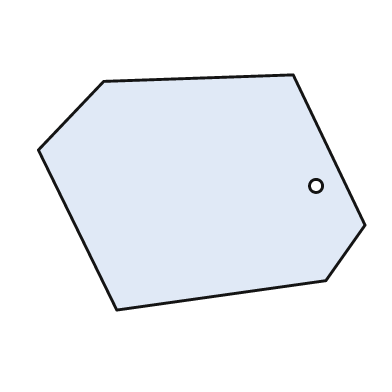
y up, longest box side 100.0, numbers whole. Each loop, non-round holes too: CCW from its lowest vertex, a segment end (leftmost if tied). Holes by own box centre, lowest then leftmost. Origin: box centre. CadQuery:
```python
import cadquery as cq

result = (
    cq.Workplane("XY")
    .moveTo(-26.0, -36.0)
    .lineTo(38.0, -27.0)
    .lineTo(50.0, -10.0)
    .lineTo(28.0, 36.0)
    .lineTo(-30.0, 34.0)
    .lineTo(-50.0, 13.0)
    .close()
    .moveTo(35.0, 2.0)
    .circle(2.0)
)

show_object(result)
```